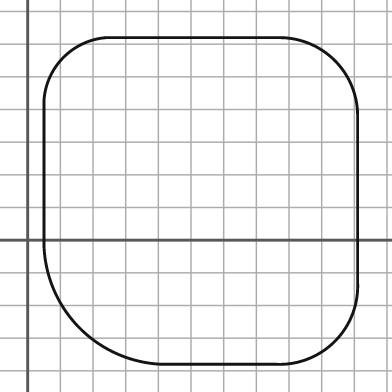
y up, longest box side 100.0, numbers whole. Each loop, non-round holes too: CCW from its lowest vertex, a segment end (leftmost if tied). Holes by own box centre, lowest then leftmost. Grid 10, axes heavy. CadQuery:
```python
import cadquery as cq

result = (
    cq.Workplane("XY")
    .moveTo(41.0, -38.0)
    .lineTo(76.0, -38.0)
    .threePointArc((94.0, -31.0), (101.0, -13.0))
    .lineTo(101.0, 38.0)
    .threePointArc((94.0, 55.0), (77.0, 62.0))
    .lineTo(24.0, 62.0)
    .threePointArc((11.0, 56.0), (5.0, 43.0))
    .lineTo(5.0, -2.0)
    .threePointArc((16.0, -27.0), (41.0, -38.0))
    .close()
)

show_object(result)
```